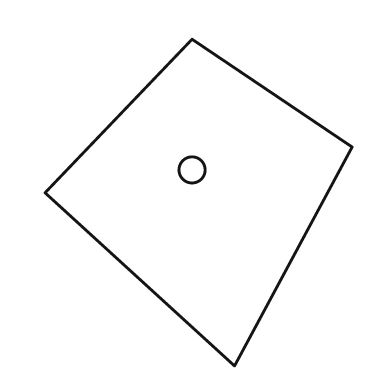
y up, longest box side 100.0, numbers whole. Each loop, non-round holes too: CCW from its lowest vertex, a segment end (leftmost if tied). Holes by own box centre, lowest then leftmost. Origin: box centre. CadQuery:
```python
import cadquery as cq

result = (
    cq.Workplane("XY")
    .moveTo(11.0, -50.0)
    .lineTo(47.0, 17.0)
    .lineTo(-2.0, 50.0)
    .lineTo(-47.0, 3.0)
    .close()
    .moveTo(-2.0, 10.0)
    .circle(4.0)
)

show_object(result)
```